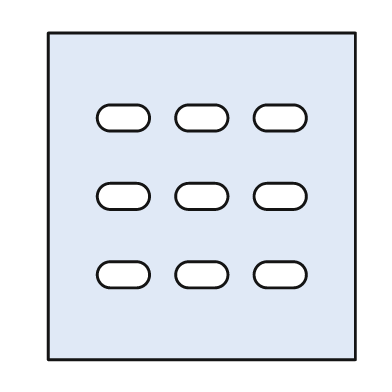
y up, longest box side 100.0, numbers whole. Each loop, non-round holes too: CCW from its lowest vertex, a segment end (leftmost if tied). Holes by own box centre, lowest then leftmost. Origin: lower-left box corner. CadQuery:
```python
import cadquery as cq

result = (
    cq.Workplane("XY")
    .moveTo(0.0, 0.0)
    .lineTo(94.0, 0.0)
    .lineTo(94.0, 100.0)
    .lineTo(0.0, 100.0)
    .close()
    .moveTo(19.0, 22.0)
    .lineTo(27.0, 22.0)
    .threePointArc((31.0, 26.0), (27.0, 30.0))
    .lineTo(19.0, 30.0)
    .threePointArc((15.0, 26.0), (19.0, 22.0))
    .close()
    .moveTo(43.0, 22.0)
    .lineTo(51.0, 22.0)
    .threePointArc((55.0, 26.0), (51.0, 30.0))
    .lineTo(43.0, 30.0)
    .threePointArc((39.0, 26.0), (43.0, 22.0))
    .close()
    .moveTo(67.0, 22.0)
    .lineTo(75.0, 22.0)
    .threePointArc((79.0, 26.0), (75.0, 30.0))
    .lineTo(67.0, 30.0)
    .threePointArc((63.0, 26.0), (67.0, 22.0))
    .close()
    .moveTo(19.0, 46.0)
    .lineTo(27.0, 46.0)
    .threePointArc((31.0, 50.0), (27.0, 54.0))
    .lineTo(19.0, 54.0)
    .threePointArc((15.0, 50.0), (19.0, 46.0))
    .close()
    .moveTo(43.0, 46.0)
    .lineTo(51.0, 46.0)
    .threePointArc((55.0, 50.0), (51.0, 54.0))
    .lineTo(43.0, 54.0)
    .threePointArc((39.0, 50.0), (43.0, 46.0))
    .close()
    .moveTo(67.0, 46.0)
    .lineTo(75.0, 46.0)
    .threePointArc((79.0, 50.0), (75.0, 54.0))
    .lineTo(67.0, 54.0)
    .threePointArc((63.0, 50.0), (67.0, 46.0))
    .close()
    .moveTo(19.0, 70.0)
    .lineTo(27.0, 70.0)
    .threePointArc((31.0, 74.0), (27.0, 78.0))
    .lineTo(19.0, 78.0)
    .threePointArc((15.0, 74.0), (19.0, 70.0))
    .close()
    .moveTo(43.0, 70.0)
    .lineTo(51.0, 70.0)
    .threePointArc((55.0, 74.0), (51.0, 78.0))
    .lineTo(43.0, 78.0)
    .threePointArc((39.0, 74.0), (43.0, 70.0))
    .close()
    .moveTo(67.0, 70.0)
    .lineTo(75.0, 70.0)
    .threePointArc((79.0, 74.0), (75.0, 78.0))
    .lineTo(67.0, 78.0)
    .threePointArc((63.0, 74.0), (67.0, 70.0))
    .close()
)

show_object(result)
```